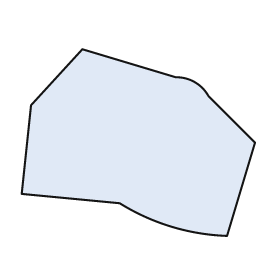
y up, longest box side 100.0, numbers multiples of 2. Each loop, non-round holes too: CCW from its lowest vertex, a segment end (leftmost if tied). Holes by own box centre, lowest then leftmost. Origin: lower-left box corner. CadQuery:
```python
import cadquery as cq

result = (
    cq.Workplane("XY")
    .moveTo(88.0, 0.0)
    .lineTo(100.0, 40.0)
    .lineTo(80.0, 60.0)
    .threePointArc((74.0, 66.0), (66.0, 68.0))
    .lineTo(26.0, 80.0)
    .lineTo(4.0, 56.0)
    .lineTo(0.0, 18.0)
    .lineTo(42.0, 14.0)
    .threePointArc((64.0, 4.0), (88.0, 0.0))
    .close()
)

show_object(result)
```